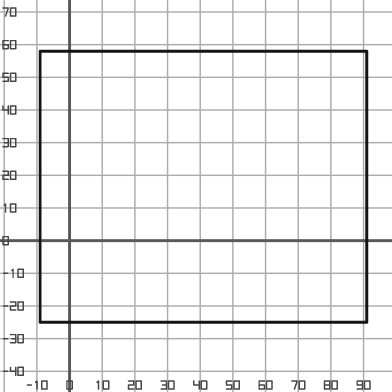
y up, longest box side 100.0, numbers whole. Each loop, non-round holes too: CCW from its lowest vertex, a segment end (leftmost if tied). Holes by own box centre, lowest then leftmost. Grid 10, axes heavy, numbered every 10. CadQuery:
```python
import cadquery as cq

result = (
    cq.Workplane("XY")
    .moveTo(-9.0, -25.0)
    .lineTo(91.0, -25.0)
    .lineTo(91.0, 58.0)
    .lineTo(-9.0, 58.0)
    .close()
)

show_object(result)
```